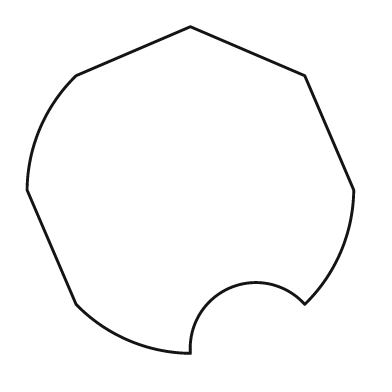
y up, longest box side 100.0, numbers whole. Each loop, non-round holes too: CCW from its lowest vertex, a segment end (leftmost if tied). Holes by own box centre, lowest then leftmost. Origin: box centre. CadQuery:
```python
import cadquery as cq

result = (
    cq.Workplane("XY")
    .moveTo(0.0, -50.0)
    .threePointArc((12.0, -30.0), (35.0, -35.0))
    .threePointArc((46.0, -19.0), (50.0, 0.0))
    .lineTo(35.0, 35.0)
    .lineTo(0.0, 50.0)
    .lineTo(-35.0, 35.0)
    .threePointArc((-46.0, 19.0), (-50.0, 0.0))
    .lineTo(-35.0, -35.0)
    .threePointArc((-19.0, -46.0), (0.0, -50.0))
    .close()
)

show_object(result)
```